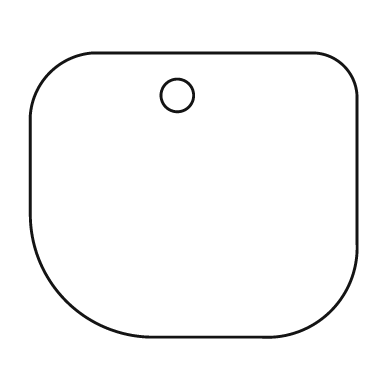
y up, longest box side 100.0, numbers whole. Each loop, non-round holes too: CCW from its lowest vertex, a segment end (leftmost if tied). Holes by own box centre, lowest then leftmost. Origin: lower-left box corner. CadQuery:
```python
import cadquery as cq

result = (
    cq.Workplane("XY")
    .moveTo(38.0, 0.0)
    .lineTo(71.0, 0.0)
    .threePointArc((92.0, 8.0), (100.0, 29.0))
    .lineTo(100.0, 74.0)
    .threePointArc((96.0, 83.0), (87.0, 87.0))
    .lineTo(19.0, 87.0)
    .threePointArc((6.0, 81.0), (0.0, 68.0))
    .lineTo(0.0, 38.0)
    .threePointArc((11.0, 11.0), (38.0, 0.0))
    .close()
    .moveTo(45.0, 74.0)
    .circle(5.0)
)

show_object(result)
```